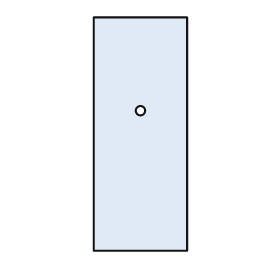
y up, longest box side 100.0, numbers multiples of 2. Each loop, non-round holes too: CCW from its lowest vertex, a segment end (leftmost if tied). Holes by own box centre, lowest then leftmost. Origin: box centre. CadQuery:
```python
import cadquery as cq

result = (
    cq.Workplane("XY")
    .moveTo(-20.0, -50.0)
    .lineTo(20.0, -50.0)
    .lineTo(20.0, 50.0)
    .lineTo(-20.0, 50.0)
    .close()
    .moveTo(0.0, 10.0)
    .circle(2.0)
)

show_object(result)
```